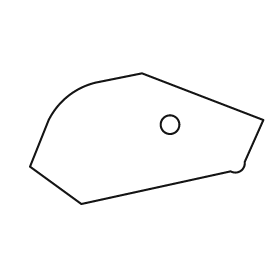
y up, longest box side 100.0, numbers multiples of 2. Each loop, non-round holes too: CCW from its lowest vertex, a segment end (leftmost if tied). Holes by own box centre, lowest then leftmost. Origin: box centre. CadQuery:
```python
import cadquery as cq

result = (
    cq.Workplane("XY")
    .moveTo(-28.0, -28.0)
    .lineTo(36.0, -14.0)
    .threePointArc((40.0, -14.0), (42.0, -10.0))
    .lineTo(50.0, 8.0)
    .lineTo(-2.0, 28.0)
    .lineTo(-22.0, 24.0)
    .threePointArc((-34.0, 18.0), (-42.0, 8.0))
    .lineTo(-50.0, -12.0)
    .close()
    .moveTo(10.0, 6.0)
    .circle(4.0)
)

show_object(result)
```